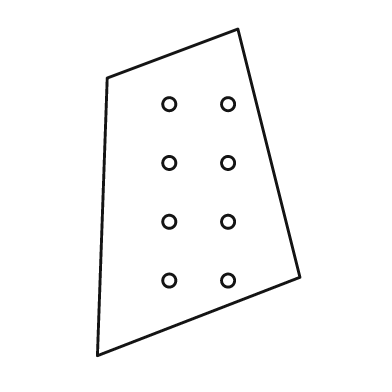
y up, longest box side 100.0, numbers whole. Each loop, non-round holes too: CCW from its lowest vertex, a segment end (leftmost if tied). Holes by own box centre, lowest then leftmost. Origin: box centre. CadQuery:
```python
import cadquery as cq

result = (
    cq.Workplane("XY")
    .moveTo(-31.0, -50.0)
    .lineTo(31.0, -26.0)
    .lineTo(12.0, 50.0)
    .lineTo(-28.0, 35.0)
    .close()
    .moveTo(-9.0, -27.0)
    .circle(2.0)
    .moveTo(9.0, -27.0)
    .circle(2.0)
    .moveTo(-9.0, -9.0)
    .circle(2.0)
    .moveTo(9.0, -9.0)
    .circle(2.0)
    .moveTo(-9.0, 9.0)
    .circle(2.0)
    .moveTo(9.0, 9.0)
    .circle(2.0)
    .moveTo(-9.0, 27.0)
    .circle(2.0)
    .moveTo(9.0, 27.0)
    .circle(2.0)
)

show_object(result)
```